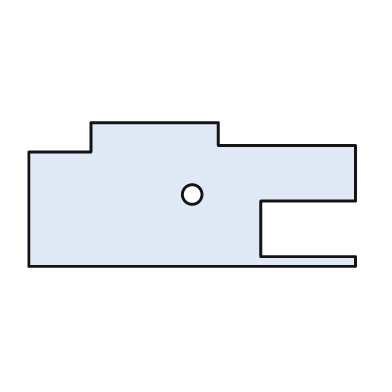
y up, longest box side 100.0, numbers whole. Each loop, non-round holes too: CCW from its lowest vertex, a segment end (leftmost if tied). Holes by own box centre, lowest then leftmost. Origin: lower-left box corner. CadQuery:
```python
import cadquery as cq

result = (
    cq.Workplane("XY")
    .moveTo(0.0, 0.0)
    .lineTo(100.0, 0.0)
    .lineTo(100.0, 3.0)
    .lineTo(71.0, 3.0)
    .lineTo(71.0, 20.0)
    .lineTo(100.0, 20.0)
    .lineTo(100.0, 37.0)
    .lineTo(58.0, 37.0)
    .lineTo(58.0, 44.0)
    .lineTo(19.0, 44.0)
    .lineTo(19.0, 35.0)
    .lineTo(0.0, 35.0)
    .close()
    .moveTo(50.0, 22.0)
    .circle(3.0)
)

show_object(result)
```